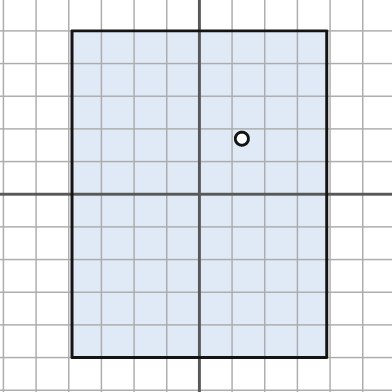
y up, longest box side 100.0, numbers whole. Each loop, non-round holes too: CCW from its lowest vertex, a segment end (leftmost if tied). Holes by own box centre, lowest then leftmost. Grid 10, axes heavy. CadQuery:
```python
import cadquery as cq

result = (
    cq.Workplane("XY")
    .moveTo(-39.0, -50.0)
    .lineTo(39.0, -50.0)
    .lineTo(39.0, 50.0)
    .lineTo(-39.0, 50.0)
    .close()
    .moveTo(13.0, 17.0)
    .circle(2.0)
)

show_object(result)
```